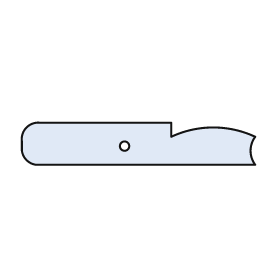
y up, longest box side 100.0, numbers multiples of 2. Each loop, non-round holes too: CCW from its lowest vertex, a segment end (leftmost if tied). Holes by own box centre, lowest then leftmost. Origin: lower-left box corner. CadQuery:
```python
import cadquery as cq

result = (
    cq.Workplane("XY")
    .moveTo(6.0, 0.0)
    .lineTo(100.0, 0.0)
    .threePointArc((98.0, 6.0), (100.0, 12.0))
    .threePointArc((82.0, 16.0), (64.0, 12.0))
    .lineTo(64.0, 18.0)
    .lineTo(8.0, 18.0)
    .threePointArc((2.0, 16.0), (0.0, 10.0))
    .lineTo(0.0, 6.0)
    .threePointArc((2.0, 2.0), (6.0, 0.0))
    .close()
    .moveTo(44.0, 8.0)
    .circle(2.0)
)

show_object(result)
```